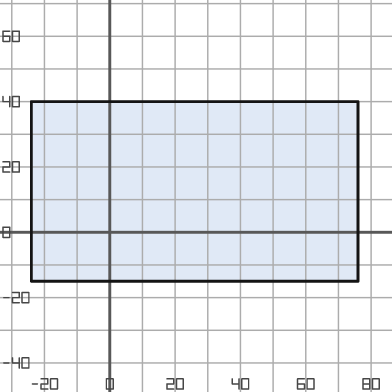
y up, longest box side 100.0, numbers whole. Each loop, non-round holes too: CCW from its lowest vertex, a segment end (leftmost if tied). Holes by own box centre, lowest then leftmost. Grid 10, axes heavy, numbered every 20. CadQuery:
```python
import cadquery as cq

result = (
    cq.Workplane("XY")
    .moveTo(-24.0, -15.0)
    .lineTo(76.0, -15.0)
    .lineTo(76.0, 40.0)
    .lineTo(-24.0, 40.0)
    .close()
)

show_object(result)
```